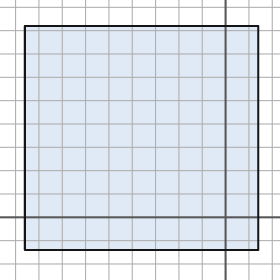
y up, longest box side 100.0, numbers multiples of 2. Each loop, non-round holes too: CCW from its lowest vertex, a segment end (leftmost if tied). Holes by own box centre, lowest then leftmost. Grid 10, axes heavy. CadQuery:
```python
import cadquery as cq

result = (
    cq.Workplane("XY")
    .moveTo(-86.0, -14.0)
    .lineTo(14.0, -14.0)
    .lineTo(14.0, 82.0)
    .lineTo(-86.0, 82.0)
    .close()
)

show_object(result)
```